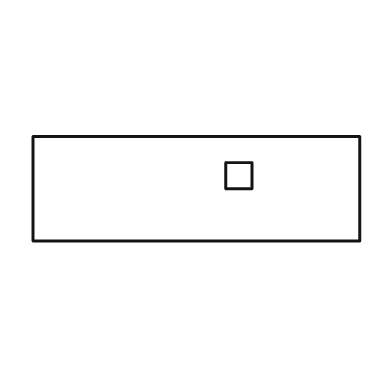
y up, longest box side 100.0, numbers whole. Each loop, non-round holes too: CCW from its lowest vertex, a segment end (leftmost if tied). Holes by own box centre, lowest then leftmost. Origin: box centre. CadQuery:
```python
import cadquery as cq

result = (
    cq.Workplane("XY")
    .moveTo(-50.0, -16.0)
    .lineTo(50.0, -16.0)
    .lineTo(50.0, 16.0)
    .lineTo(-50.0, 16.0)
    .close()
    .moveTo(9.0, 0.0)
    .lineTo(17.0, 0.0)
    .lineTo(17.0, 8.0)
    .lineTo(9.0, 8.0)
    .close()
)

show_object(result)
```